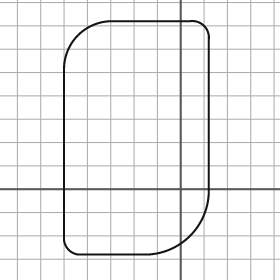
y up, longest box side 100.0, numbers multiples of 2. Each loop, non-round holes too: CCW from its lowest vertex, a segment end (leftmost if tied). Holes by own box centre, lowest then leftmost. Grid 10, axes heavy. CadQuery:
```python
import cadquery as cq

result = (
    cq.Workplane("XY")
    .moveTo(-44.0, -28.0)
    .lineTo(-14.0, -28.0)
    .threePointArc((4.0, -20.0), (12.0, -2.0))
    .lineTo(12.0, 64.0)
    .threePointArc((10.0, 70.0), (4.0, 72.0))
    .lineTo(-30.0, 72.0)
    .threePointArc((-44.0, 66.0), (-50.0, 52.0))
    .lineTo(-50.0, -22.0)
    .threePointArc((-48.0, -26.0), (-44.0, -28.0))
    .close()
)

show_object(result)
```